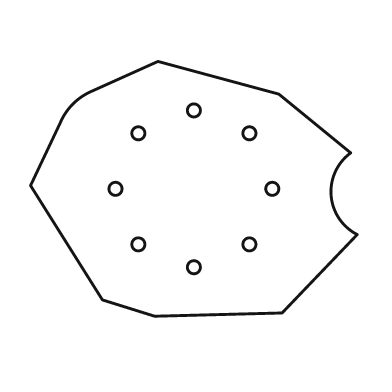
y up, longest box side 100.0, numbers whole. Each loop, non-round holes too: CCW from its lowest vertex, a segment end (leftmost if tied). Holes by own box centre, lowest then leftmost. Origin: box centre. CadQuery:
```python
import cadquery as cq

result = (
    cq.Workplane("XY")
    .moveTo(-12.0, -39.0)
    .lineTo(27.0, -38.0)
    .lineTo(50.0, -14.0)
    .threePointArc((42.0, -2.0), (48.0, 11.0))
    .lineTo(26.0, 29.0)
    .lineTo(-11.0, 39.0)
    .lineTo(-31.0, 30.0)
    .threePointArc((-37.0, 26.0), (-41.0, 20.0))
    .lineTo(-50.0, 1.0)
    .lineTo(-28.0, -34.0)
    .close()
    .moveTo(0.0, -24.0)
    .circle(2.0)
    .moveTo(-17.0, -17.0)
    .circle(2.0)
    .moveTo(17.0, -17.0)
    .circle(2.0)
    .moveTo(-24.0, 0.0)
    .circle(2.0)
    .moveTo(24.0, 0.0)
    .circle(2.0)
    .moveTo(-17.0, 17.0)
    .circle(2.0)
    .moveTo(17.0, 17.0)
    .circle(2.0)
    .moveTo(0.0, 24.0)
    .circle(2.0)
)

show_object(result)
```